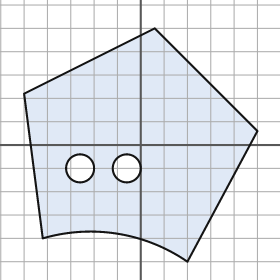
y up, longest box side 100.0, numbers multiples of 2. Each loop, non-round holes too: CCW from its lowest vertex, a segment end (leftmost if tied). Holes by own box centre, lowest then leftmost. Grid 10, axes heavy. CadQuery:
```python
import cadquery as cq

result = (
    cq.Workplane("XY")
    .moveTo(20.0, -50.0)
    .lineTo(50.0, 6.0)
    .lineTo(6.0, 50.0)
    .lineTo(-50.0, 22.0)
    .lineTo(-42.0, -40.0)
    .threePointArc((-10.0, -38.0), (20.0, -50.0))
    .close()
    .moveTo(-26.0, -10.0)
    .circle(6.0)
    .moveTo(-6.0, -10.0)
    .circle(6.0)
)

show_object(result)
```